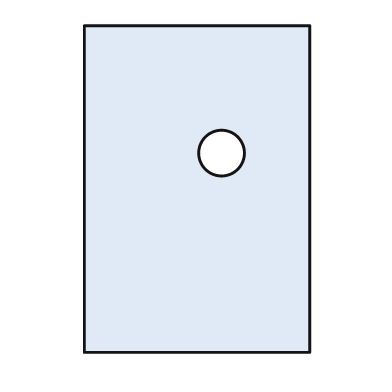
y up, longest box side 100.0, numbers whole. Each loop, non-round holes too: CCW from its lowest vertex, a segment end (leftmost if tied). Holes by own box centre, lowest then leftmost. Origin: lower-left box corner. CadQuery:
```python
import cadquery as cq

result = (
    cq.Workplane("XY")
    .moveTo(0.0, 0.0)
    .lineTo(69.0, 0.0)
    .lineTo(69.0, 100.0)
    .lineTo(0.0, 100.0)
    .close()
    .moveTo(42.0, 61.0)
    .circle(7.0)
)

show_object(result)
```